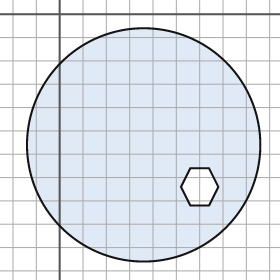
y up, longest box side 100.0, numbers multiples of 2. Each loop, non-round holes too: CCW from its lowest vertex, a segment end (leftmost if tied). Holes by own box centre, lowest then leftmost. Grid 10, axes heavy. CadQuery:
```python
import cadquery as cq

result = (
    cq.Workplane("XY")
    .moveTo(36.0, -56.0)
    .circle(50.0)
    .moveTo(56.0, -82.0)
    .lineTo(64.0, -82.0)
    .lineTo(68.0, -74.0)
    .lineTo(64.0, -66.0)
    .lineTo(56.0, -66.0)
    .lineTo(52.0, -74.0)
    .close()
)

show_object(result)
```